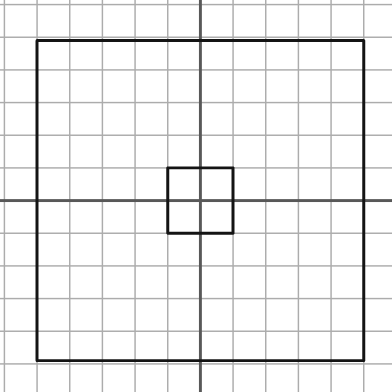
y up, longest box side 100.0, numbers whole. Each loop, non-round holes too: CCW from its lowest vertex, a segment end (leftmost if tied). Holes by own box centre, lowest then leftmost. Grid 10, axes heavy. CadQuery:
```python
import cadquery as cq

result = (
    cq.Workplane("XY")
    .moveTo(-50.0, -49.0)
    .lineTo(50.0, -49.0)
    .lineTo(50.0, 49.0)
    .lineTo(-50.0, 49.0)
    .close()
    .moveTo(-10.0, -10.0)
    .lineTo(10.0, -10.0)
    .lineTo(10.0, 10.0)
    .lineTo(-10.0, 10.0)
    .close()
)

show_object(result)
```